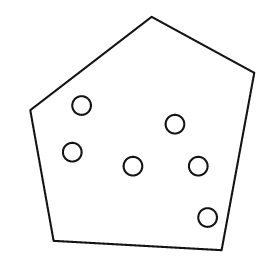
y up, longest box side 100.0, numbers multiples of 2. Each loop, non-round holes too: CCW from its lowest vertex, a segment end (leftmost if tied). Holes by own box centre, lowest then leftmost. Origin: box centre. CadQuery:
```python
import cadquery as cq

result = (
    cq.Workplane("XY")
    .moveTo(34.0, -50.0)
    .lineTo(48.0, 26.0)
    .lineTo(4.0, 50.0)
    .lineTo(-48.0, 10.0)
    .lineTo(-38.0, -46.0)
    .close()
    .moveTo(28.0, -36.0)
    .circle(4.0)
    .moveTo(-4.0, -14.0)
    .circle(4.0)
    .moveTo(24.0, -14.0)
    .circle(4.0)
    .moveTo(-30.0, -8.0)
    .circle(4.0)
    .moveTo(14.0, 4.0)
    .circle(4.0)
    .moveTo(-26.0, 12.0)
    .circle(4.0)
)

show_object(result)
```